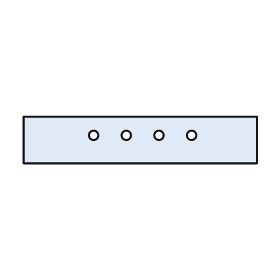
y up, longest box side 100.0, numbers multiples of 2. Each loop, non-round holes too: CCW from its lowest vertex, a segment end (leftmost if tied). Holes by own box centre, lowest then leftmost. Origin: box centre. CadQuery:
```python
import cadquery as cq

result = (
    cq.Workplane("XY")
    .moveTo(-50.0, -10.0)
    .lineTo(50.0, -10.0)
    .lineTo(50.0, 10.0)
    .lineTo(-50.0, 10.0)
    .close()
    .moveTo(-20.0, 2.0)
    .circle(2.0)
    .moveTo(-6.0, 2.0)
    .circle(2.0)
    .moveTo(8.0, 2.0)
    .circle(2.0)
    .moveTo(22.0, 2.0)
    .circle(2.0)
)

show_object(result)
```